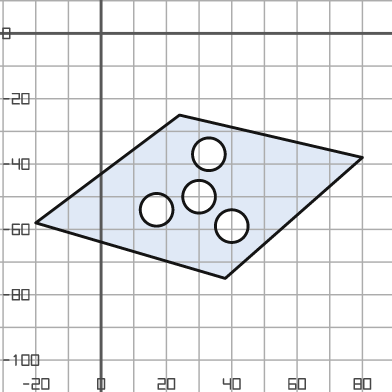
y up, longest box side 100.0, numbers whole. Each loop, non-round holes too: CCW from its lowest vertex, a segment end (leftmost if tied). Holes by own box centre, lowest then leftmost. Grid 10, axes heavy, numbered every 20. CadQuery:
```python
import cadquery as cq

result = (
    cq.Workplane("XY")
    .moveTo(38.0, -75.0)
    .lineTo(80.0, -38.0)
    .lineTo(24.0, -25.0)
    .lineTo(-20.0, -58.0)
    .close()
    .moveTo(40.0, -59.0)
    .circle(5.0)
    .moveTo(17.0, -54.0)
    .circle(5.0)
    .moveTo(30.0, -50.0)
    .circle(5.0)
    .moveTo(33.0, -37.0)
    .circle(5.0)
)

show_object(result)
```